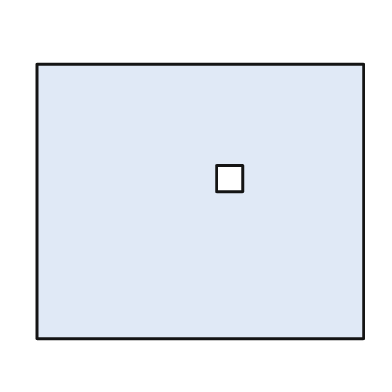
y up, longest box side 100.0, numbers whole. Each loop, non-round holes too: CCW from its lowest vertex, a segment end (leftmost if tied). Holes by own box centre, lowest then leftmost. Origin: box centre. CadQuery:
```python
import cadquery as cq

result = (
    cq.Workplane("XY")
    .moveTo(-50.0, -42.0)
    .lineTo(50.0, -42.0)
    .lineTo(50.0, 42.0)
    .lineTo(-50.0, 42.0)
    .close()
    .moveTo(5.0, 3.0)
    .lineTo(13.0, 3.0)
    .lineTo(13.0, 11.0)
    .lineTo(5.0, 11.0)
    .close()
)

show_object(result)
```